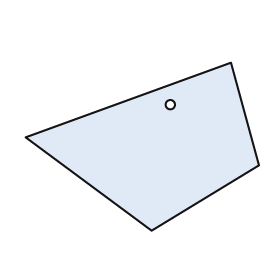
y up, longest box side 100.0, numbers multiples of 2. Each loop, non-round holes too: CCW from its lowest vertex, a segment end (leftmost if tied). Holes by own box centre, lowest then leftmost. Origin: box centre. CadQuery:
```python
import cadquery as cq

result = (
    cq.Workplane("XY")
    .moveTo(4.0, -36.0)
    .lineTo(50.0, -8.0)
    .lineTo(38.0, 36.0)
    .lineTo(-50.0, 4.0)
    .close()
    .moveTo(12.0, 18.0)
    .circle(2.0)
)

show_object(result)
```